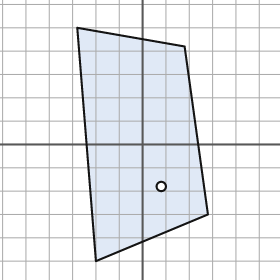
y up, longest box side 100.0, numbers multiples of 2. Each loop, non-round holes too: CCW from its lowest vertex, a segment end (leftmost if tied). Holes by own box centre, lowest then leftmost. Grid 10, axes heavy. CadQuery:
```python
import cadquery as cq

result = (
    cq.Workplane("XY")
    .moveTo(-20.0, -50.0)
    .lineTo(28.0, -30.0)
    .lineTo(18.0, 42.0)
    .lineTo(-28.0, 50.0)
    .close()
    .moveTo(8.0, -18.0)
    .circle(2.0)
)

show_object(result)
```